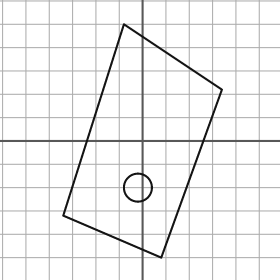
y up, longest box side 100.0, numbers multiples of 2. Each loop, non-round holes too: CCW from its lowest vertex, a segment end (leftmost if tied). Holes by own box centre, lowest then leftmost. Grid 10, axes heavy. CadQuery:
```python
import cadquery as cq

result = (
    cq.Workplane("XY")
    .moveTo(8.0, -50.0)
    .lineTo(34.0, 22.0)
    .lineTo(-8.0, 50.0)
    .lineTo(-34.0, -32.0)
    .close()
    .moveTo(-2.0, -20.0)
    .circle(6.0)
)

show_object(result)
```